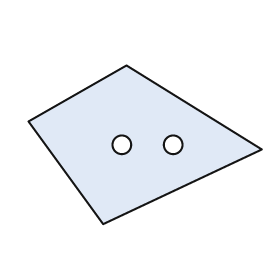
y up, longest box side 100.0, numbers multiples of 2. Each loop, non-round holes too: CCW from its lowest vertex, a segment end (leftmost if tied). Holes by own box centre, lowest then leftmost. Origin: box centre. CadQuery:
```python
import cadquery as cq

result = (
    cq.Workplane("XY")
    .moveTo(-18.0, -34.0)
    .lineTo(50.0, -2.0)
    .lineTo(-8.0, 34.0)
    .lineTo(-50.0, 10.0)
    .close()
    .moveTo(-10.0, 0.0)
    .circle(4.0)
    .moveTo(12.0, 0.0)
    .circle(4.0)
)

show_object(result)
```